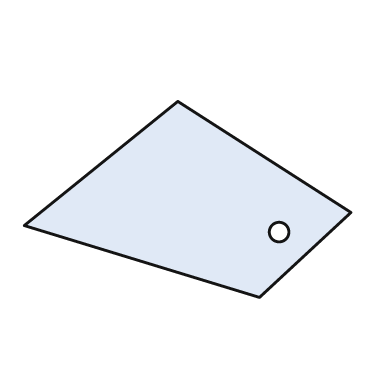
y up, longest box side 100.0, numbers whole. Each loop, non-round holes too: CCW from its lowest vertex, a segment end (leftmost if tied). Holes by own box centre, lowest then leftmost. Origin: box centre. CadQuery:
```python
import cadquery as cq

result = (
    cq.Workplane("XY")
    .moveTo(22.0, -30.0)
    .lineTo(50.0, -4.0)
    .lineTo(-3.0, 30.0)
    .lineTo(-50.0, -8.0)
    .close()
    .moveTo(28.0, -10.0)
    .circle(3.0)
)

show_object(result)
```